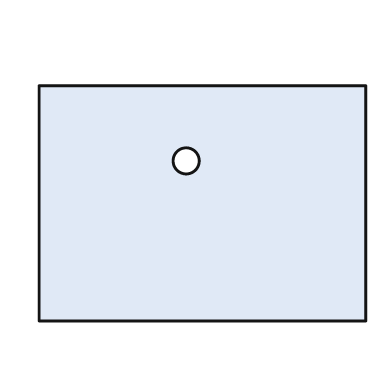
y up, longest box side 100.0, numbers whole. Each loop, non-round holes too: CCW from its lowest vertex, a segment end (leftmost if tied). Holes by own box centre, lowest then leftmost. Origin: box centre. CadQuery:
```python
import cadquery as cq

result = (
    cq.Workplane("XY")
    .moveTo(-50.0, -36.0)
    .lineTo(50.0, -36.0)
    .lineTo(50.0, 36.0)
    .lineTo(-50.0, 36.0)
    .close()
    .moveTo(-5.0, 13.0)
    .circle(4.0)
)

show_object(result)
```